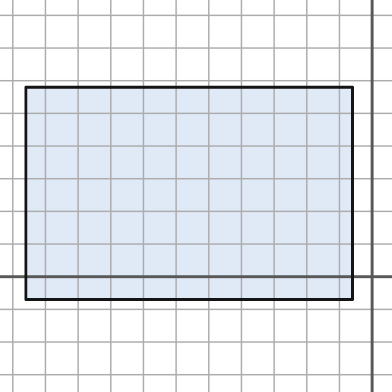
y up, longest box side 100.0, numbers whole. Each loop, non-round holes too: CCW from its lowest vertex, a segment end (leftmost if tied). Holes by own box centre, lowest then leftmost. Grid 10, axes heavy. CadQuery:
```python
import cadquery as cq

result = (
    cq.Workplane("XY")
    .moveTo(-106.0, -7.0)
    .lineTo(-6.0, -7.0)
    .lineTo(-6.0, 58.0)
    .lineTo(-106.0, 58.0)
    .close()
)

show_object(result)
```